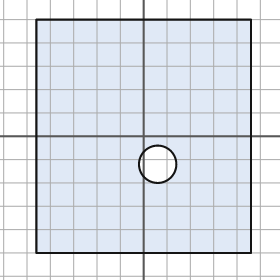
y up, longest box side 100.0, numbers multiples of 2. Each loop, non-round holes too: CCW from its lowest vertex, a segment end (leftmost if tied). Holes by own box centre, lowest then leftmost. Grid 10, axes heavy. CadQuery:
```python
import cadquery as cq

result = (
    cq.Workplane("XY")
    .moveTo(-46.0, -50.0)
    .lineTo(46.0, -50.0)
    .lineTo(46.0, 50.0)
    .lineTo(-46.0, 50.0)
    .close()
    .moveTo(6.0, -12.0)
    .circle(8.0)
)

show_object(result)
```